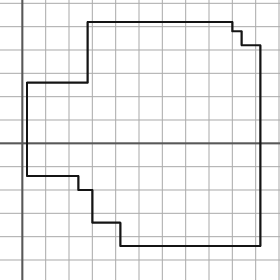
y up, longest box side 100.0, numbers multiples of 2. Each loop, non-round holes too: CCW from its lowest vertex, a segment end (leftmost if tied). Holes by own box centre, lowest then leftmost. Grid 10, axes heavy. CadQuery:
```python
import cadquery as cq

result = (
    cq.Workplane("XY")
    .moveTo(42.0, -44.0)
    .lineTo(102.0, -44.0)
    .lineTo(102.0, 42.0)
    .lineTo(94.0, 42.0)
    .lineTo(94.0, 48.0)
    .lineTo(90.0, 48.0)
    .lineTo(90.0, 52.0)
    .lineTo(28.0, 52.0)
    .lineTo(28.0, 26.0)
    .lineTo(2.0, 26.0)
    .lineTo(2.0, -14.0)
    .lineTo(24.0, -14.0)
    .lineTo(24.0, -20.0)
    .lineTo(30.0, -20.0)
    .lineTo(30.0, -34.0)
    .lineTo(42.0, -34.0)
    .close()
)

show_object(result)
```